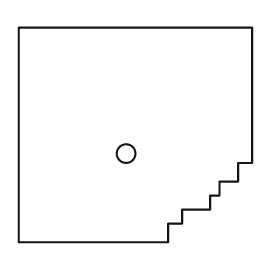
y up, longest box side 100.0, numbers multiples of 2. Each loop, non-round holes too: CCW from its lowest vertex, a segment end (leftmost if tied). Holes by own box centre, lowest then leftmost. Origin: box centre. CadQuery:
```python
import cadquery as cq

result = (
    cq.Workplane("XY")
    .moveTo(-50.0, -46.0)
    .lineTo(14.0, -46.0)
    .lineTo(14.0, -38.0)
    .lineTo(20.0, -38.0)
    .lineTo(20.0, -32.0)
    .lineTo(32.0, -32.0)
    .lineTo(32.0, -26.0)
    .lineTo(36.0, -26.0)
    .lineTo(36.0, -20.0)
    .lineTo(44.0, -20.0)
    .lineTo(44.0, -12.0)
    .lineTo(50.0, -12.0)
    .lineTo(50.0, 46.0)
    .lineTo(-50.0, 46.0)
    .close()
    .moveTo(-4.0, -8.0)
    .circle(4.0)
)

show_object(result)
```